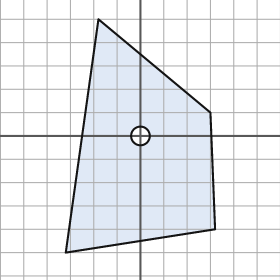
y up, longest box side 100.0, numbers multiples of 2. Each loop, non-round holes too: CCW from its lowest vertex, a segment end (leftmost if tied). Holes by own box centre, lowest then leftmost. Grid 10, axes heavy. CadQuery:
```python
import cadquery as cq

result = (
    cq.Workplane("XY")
    .moveTo(-32.0, -50.0)
    .lineTo(32.0, -40.0)
    .lineTo(30.0, 10.0)
    .lineTo(-18.0, 50.0)
    .close()
    .moveTo(0.0, 0.0)
    .circle(4.0)
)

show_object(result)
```